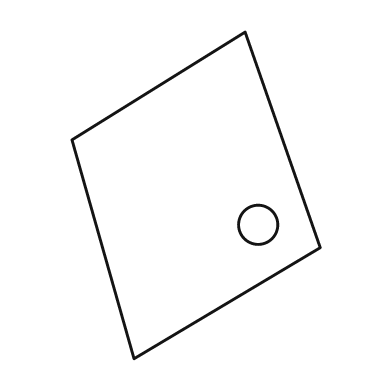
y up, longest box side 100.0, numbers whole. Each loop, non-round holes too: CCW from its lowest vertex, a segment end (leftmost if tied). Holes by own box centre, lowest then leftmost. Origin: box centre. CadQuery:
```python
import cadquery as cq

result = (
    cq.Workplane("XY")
    .moveTo(-19.0, -50.0)
    .lineTo(38.0, -16.0)
    .lineTo(15.0, 50.0)
    .lineTo(-38.0, 17.0)
    .close()
    .moveTo(19.0, -9.0)
    .circle(6.0)
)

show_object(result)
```